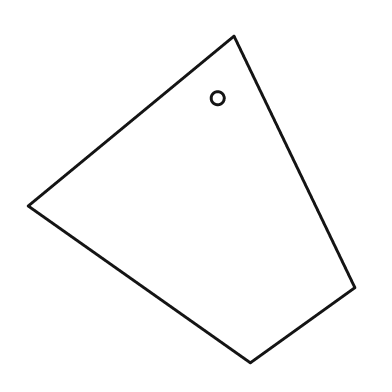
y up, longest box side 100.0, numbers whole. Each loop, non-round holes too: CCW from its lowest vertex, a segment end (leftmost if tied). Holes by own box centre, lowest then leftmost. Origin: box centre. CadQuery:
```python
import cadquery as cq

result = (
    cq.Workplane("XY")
    .moveTo(18.0, -50.0)
    .lineTo(50.0, -27.0)
    .lineTo(13.0, 50.0)
    .lineTo(-50.0, -2.0)
    .close()
    .moveTo(8.0, 31.0)
    .circle(2.0)
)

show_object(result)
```